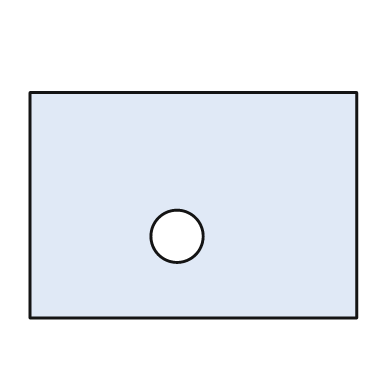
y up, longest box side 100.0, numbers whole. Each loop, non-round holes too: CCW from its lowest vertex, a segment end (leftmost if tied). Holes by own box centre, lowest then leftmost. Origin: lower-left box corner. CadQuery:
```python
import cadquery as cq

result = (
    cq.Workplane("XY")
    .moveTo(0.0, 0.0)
    .lineTo(100.0, 0.0)
    .lineTo(100.0, 69.0)
    .lineTo(0.0, 69.0)
    .close()
    .moveTo(45.0, 25.0)
    .circle(8.0)
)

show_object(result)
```